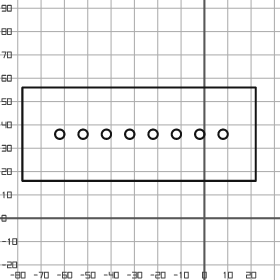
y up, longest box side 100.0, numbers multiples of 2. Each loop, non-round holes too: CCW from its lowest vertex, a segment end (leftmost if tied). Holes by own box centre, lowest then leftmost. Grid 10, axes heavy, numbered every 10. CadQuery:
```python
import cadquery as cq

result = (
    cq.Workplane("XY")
    .moveTo(-78.0, 16.0)
    .lineTo(22.0, 16.0)
    .lineTo(22.0, 56.0)
    .lineTo(-78.0, 56.0)
    .close()
    .moveTo(-62.0, 36.0)
    .circle(2.0)
    .moveTo(-52.0, 36.0)
    .circle(2.0)
    .moveTo(-42.0, 36.0)
    .circle(2.0)
    .moveTo(-32.0, 36.0)
    .circle(2.0)
    .moveTo(-22.0, 36.0)
    .circle(2.0)
    .moveTo(-12.0, 36.0)
    .circle(2.0)
    .moveTo(-2.0, 36.0)
    .circle(2.0)
    .moveTo(8.0, 36.0)
    .circle(2.0)
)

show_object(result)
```